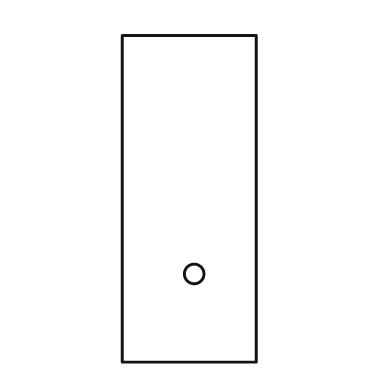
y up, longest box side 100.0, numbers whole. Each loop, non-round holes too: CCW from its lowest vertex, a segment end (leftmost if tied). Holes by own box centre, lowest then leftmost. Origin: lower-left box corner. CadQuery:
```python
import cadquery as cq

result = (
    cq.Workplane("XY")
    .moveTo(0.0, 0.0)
    .lineTo(41.0, 0.0)
    .lineTo(41.0, 100.0)
    .lineTo(0.0, 100.0)
    .close()
    .moveTo(22.0, 27.0)
    .circle(3.0)
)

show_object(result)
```